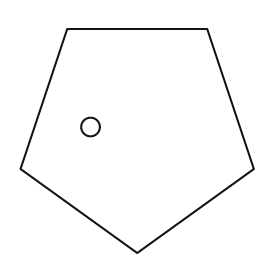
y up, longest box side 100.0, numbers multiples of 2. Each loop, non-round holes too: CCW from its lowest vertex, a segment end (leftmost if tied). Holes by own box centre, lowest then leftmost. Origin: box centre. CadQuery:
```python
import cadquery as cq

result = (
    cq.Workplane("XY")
    .moveTo(0.0, -48.0)
    .lineTo(50.0, -12.0)
    .lineTo(30.0, 48.0)
    .lineTo(-30.0, 48.0)
    .lineTo(-50.0, -12.0)
    .close()
    .moveTo(-20.0, 6.0)
    .circle(4.0)
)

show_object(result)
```